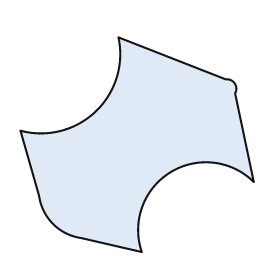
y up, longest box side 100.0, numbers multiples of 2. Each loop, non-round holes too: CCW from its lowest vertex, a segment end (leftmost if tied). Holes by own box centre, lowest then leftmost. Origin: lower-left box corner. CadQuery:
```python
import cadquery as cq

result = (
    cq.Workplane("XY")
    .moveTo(52.0, 0.0)
    .threePointArc((64.0, 34.0), (100.0, 30.0))
    .lineTo(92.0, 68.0)
    .threePointArc((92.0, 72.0), (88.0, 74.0))
    .lineTo(42.0, 92.0)
    .threePointArc((32.0, 60.0), (0.0, 52.0))
    .lineTo(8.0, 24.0)
    .threePointArc((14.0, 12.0), (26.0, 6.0))
    .close()
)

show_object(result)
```